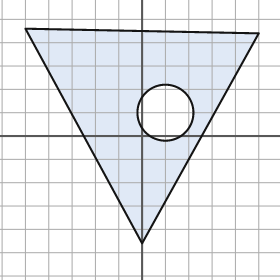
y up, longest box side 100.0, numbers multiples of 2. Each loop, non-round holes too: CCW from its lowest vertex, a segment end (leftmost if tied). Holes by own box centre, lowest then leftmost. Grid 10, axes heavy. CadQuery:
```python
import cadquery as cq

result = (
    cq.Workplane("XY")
    .moveTo(0.0, -46.0)
    .lineTo(50.0, 44.0)
    .lineTo(-50.0, 46.0)
    .close()
    .moveTo(10.0, 10.0)
    .circle(12.0)
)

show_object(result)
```